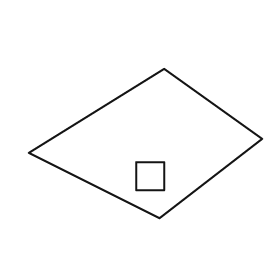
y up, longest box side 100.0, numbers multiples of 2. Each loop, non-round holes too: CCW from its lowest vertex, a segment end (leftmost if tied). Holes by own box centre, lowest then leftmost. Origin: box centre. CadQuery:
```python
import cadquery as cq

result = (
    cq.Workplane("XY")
    .moveTo(6.0, -32.0)
    .lineTo(50.0, 2.0)
    .lineTo(8.0, 32.0)
    .lineTo(-50.0, -4.0)
    .close()
    .moveTo(-4.0, -20.0)
    .lineTo(8.0, -20.0)
    .lineTo(8.0, -8.0)
    .lineTo(-4.0, -8.0)
    .close()
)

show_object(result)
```